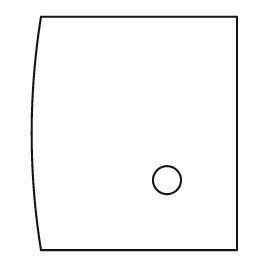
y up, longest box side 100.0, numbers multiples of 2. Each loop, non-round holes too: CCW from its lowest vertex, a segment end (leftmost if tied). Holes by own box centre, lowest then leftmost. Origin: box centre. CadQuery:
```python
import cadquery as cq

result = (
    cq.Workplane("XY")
    .moveTo(-40.0, -50.0)
    .lineTo(44.0, -50.0)
    .lineTo(44.0, 50.0)
    .lineTo(-40.0, 50.0)
    .threePointArc((-44.0, 0.0), (-40.0, -50.0))
    .close()
    .moveTo(14.0, -20.0)
    .circle(6.0)
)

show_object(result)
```